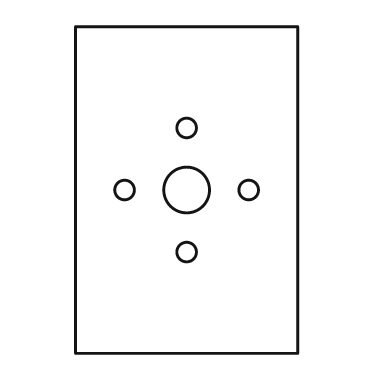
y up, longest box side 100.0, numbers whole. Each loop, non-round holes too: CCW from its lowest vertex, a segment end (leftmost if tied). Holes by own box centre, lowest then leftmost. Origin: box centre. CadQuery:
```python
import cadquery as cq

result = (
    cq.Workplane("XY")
    .moveTo(-34.0, -50.0)
    .lineTo(34.0, -50.0)
    .lineTo(34.0, 50.0)
    .lineTo(-34.0, 50.0)
    .close()
    .moveTo(0.0, -19.0)
    .circle(3.0)
    .moveTo(-19.0, 0.0)
    .circle(3.0)
    .moveTo(0.0, 0.0)
    .circle(7.0)
    .moveTo(19.0, 0.0)
    .circle(3.0)
    .moveTo(0.0, 19.0)
    .circle(3.0)
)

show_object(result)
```